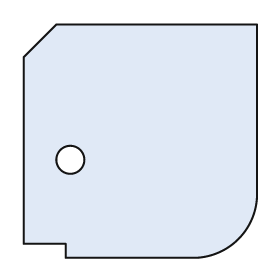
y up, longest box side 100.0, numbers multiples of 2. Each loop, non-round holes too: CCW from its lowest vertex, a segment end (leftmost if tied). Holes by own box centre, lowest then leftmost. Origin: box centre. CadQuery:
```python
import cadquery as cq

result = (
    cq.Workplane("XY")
    .moveTo(-32.0, -50.0)
    .lineTo(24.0, -50.0)
    .threePointArc((42.0, -42.0), (50.0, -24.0))
    .lineTo(50.0, 50.0)
    .lineTo(-36.0, 50.0)
    .lineTo(-50.0, 36.0)
    .lineTo(-50.0, -44.0)
    .lineTo(-32.0, -44.0)
    .close()
    .moveTo(-30.0, -8.0)
    .circle(6.0)
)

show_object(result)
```